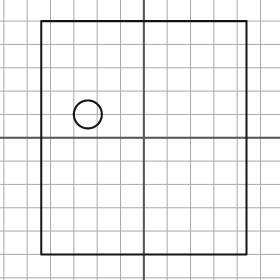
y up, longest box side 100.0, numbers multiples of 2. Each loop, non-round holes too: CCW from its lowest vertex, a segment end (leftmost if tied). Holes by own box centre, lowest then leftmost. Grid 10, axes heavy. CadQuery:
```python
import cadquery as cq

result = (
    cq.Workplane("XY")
    .moveTo(-44.0, -50.0)
    .lineTo(44.0, -50.0)
    .lineTo(44.0, 50.0)
    .lineTo(-44.0, 50.0)
    .close()
    .moveTo(-24.0, 10.0)
    .circle(6.0)
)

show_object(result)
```